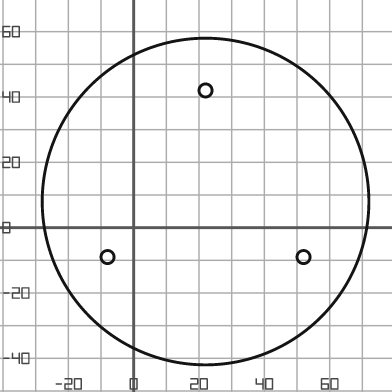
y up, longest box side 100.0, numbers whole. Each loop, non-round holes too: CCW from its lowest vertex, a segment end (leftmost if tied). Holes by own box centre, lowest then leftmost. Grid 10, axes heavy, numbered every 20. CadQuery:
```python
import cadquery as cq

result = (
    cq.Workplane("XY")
    .moveTo(22.0, 8.0)
    .circle(50.0)
    .moveTo(-8.0, -9.0)
    .circle(2.0)
    .moveTo(52.0, -9.0)
    .circle(2.0)
    .moveTo(22.0, 42.0)
    .circle(2.0)
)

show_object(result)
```